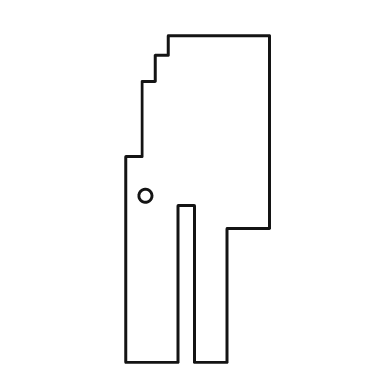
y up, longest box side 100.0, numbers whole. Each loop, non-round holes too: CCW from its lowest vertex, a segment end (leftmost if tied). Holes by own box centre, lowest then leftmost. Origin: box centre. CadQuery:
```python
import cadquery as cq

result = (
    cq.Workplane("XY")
    .moveTo(-22.0, -50.0)
    .lineTo(-6.0, -50.0)
    .lineTo(-6.0, -2.0)
    .lineTo(-1.0, -2.0)
    .lineTo(-1.0, -50.0)
    .lineTo(9.0, -50.0)
    .lineTo(9.0, -9.0)
    .lineTo(22.0, -9.0)
    .lineTo(22.0, 50.0)
    .lineTo(-9.0, 50.0)
    .lineTo(-9.0, 44.0)
    .lineTo(-13.0, 44.0)
    .lineTo(-13.0, 36.0)
    .lineTo(-17.0, 36.0)
    .lineTo(-17.0, 13.0)
    .lineTo(-22.0, 13.0)
    .close()
    .moveTo(-16.0, 1.0)
    .circle(2.0)
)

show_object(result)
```